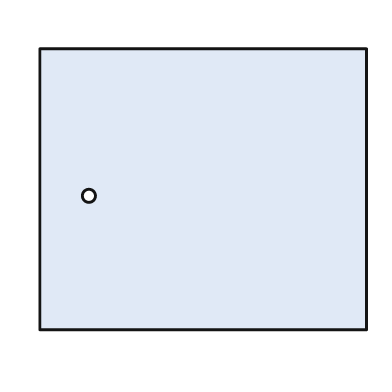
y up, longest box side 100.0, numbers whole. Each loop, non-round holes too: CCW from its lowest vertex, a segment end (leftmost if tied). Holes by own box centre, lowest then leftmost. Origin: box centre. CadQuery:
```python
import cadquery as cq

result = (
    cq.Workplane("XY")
    .moveTo(-50.0, -43.0)
    .lineTo(50.0, -43.0)
    .lineTo(50.0, 43.0)
    .lineTo(-50.0, 43.0)
    .close()
    .moveTo(-35.0, -2.0)
    .circle(2.0)
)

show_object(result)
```